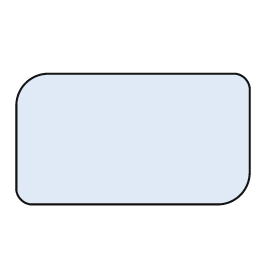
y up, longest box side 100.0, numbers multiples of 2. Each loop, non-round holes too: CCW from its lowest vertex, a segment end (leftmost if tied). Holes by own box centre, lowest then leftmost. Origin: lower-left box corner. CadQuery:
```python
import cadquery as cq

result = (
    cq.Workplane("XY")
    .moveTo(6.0, 0.0)
    .lineTo(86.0, 0.0)
    .threePointArc((96.0, 4.0), (100.0, 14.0))
    .lineTo(100.0, 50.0)
    .threePointArc((98.0, 54.0), (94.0, 56.0))
    .lineTo(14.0, 56.0)
    .threePointArc((4.0, 52.0), (0.0, 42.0))
    .lineTo(0.0, 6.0)
    .threePointArc((2.0, 2.0), (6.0, 0.0))
    .close()
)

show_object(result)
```